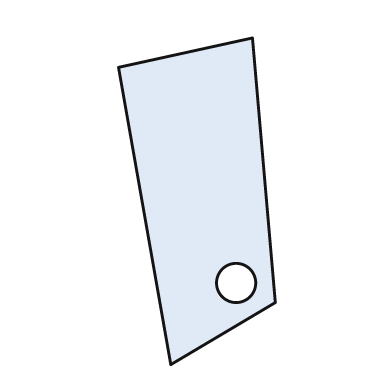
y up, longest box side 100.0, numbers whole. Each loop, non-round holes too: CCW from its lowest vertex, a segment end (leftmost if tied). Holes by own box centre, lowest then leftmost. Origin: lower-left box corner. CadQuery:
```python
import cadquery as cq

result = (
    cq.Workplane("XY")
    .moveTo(16.0, 0.0)
    .lineTo(48.0, 19.0)
    .lineTo(41.0, 100.0)
    .lineTo(0.0, 91.0)
    .close()
    .moveTo(36.0, 25.0)
    .circle(6.0)
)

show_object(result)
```